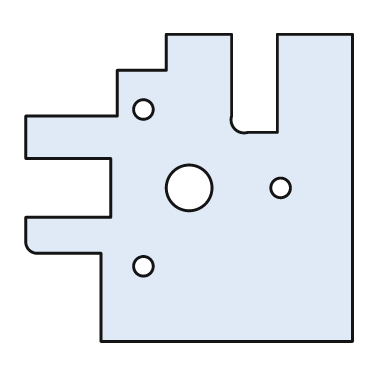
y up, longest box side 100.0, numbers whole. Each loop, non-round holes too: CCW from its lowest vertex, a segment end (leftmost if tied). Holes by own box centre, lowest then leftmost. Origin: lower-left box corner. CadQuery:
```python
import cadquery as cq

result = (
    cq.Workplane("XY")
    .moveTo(23.0, 0.0)
    .lineTo(100.0, 0.0)
    .lineTo(100.0, 94.0)
    .lineTo(77.0, 94.0)
    .lineTo(77.0, 64.0)
    .lineTo(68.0, 64.0)
    .threePointArc((64.0, 65.0), (63.0, 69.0))
    .lineTo(63.0, 94.0)
    .lineTo(43.0, 94.0)
    .lineTo(43.0, 83.0)
    .lineTo(28.0, 83.0)
    .lineTo(28.0, 69.0)
    .lineTo(0.0, 69.0)
    .lineTo(0.0, 56.0)
    .lineTo(26.0, 56.0)
    .lineTo(26.0, 38.0)
    .lineTo(0.0, 38.0)
    .lineTo(0.0, 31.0)
    .threePointArc((1.0, 28.0), (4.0, 27.0))
    .lineTo(23.0, 27.0)
    .close()
    .moveTo(36.0, 23.0)
    .circle(3.0)
    .moveTo(50.0, 47.0)
    .circle(7.0)
    .moveTo(78.0, 47.0)
    .circle(3.0)
    .moveTo(36.0, 71.0)
    .circle(3.0)
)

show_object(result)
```